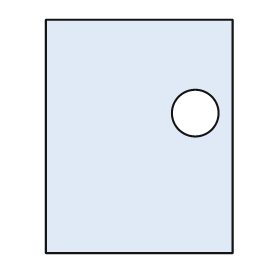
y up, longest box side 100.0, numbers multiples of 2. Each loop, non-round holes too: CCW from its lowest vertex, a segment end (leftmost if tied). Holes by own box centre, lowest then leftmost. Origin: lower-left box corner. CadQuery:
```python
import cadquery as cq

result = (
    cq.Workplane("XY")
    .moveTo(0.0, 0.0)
    .lineTo(80.0, 0.0)
    .lineTo(80.0, 100.0)
    .lineTo(0.0, 100.0)
    .close()
    .moveTo(64.0, 60.0)
    .circle(10.0)
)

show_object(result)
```